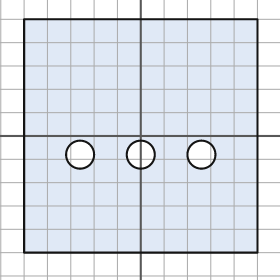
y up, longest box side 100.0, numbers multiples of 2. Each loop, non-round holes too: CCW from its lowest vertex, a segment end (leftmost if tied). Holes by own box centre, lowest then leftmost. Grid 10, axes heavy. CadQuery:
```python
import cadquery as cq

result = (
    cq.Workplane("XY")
    .moveTo(-50.0, -50.0)
    .lineTo(50.0, -50.0)
    .lineTo(50.0, 50.0)
    .lineTo(-50.0, 50.0)
    .close()
    .moveTo(-26.0, -8.0)
    .circle(6.0)
    .moveTo(0.0, -8.0)
    .circle(6.0)
    .moveTo(26.0, -8.0)
    .circle(6.0)
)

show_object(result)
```